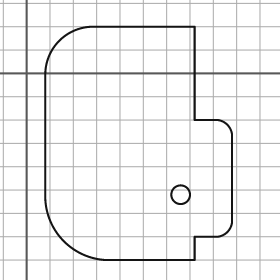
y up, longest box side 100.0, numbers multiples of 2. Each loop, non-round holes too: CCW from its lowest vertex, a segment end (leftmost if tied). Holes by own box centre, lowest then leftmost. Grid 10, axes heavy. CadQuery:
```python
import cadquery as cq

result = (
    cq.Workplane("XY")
    .moveTo(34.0, -80.0)
    .lineTo(72.0, -80.0)
    .lineTo(72.0, -70.0)
    .lineTo(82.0, -70.0)
    .threePointArc((86.0, -68.0), (88.0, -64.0))
    .lineTo(88.0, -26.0)
    .threePointArc((86.0, -22.0), (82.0, -20.0))
    .lineTo(72.0, -20.0)
    .lineTo(72.0, 20.0)
    .lineTo(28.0, 20.0)
    .threePointArc((14.0, 14.0), (8.0, 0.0))
    .lineTo(8.0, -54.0)
    .threePointArc((16.0, -72.0), (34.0, -80.0))
    .close()
    .moveTo(66.0, -52.0)
    .circle(4.0)
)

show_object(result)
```